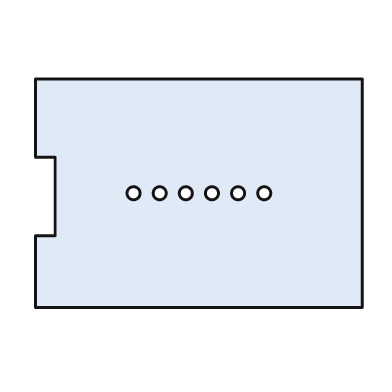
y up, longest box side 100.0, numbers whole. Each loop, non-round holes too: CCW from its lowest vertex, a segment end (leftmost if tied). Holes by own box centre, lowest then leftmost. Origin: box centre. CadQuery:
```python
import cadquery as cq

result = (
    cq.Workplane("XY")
    .moveTo(-50.0, -35.0)
    .lineTo(50.0, -35.0)
    .lineTo(50.0, 35.0)
    .lineTo(-50.0, 35.0)
    .lineTo(-50.0, 11.0)
    .lineTo(-44.0, 11.0)
    .lineTo(-44.0, -13.0)
    .lineTo(-50.0, -13.0)
    .close()
    .moveTo(-20.0, 0.0)
    .circle(2.0)
    .moveTo(-12.0, 0.0)
    .circle(2.0)
    .moveTo(-4.0, 0.0)
    .circle(2.0)
    .moveTo(4.0, 0.0)
    .circle(2.0)
    .moveTo(12.0, 0.0)
    .circle(2.0)
    .moveTo(20.0, 0.0)
    .circle(2.0)
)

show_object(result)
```